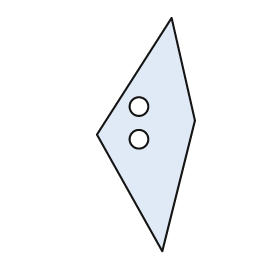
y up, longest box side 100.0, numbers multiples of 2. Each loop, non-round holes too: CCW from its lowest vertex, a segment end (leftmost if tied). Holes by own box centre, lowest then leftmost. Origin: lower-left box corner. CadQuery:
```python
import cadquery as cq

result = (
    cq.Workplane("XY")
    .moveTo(28.0, 0.0)
    .lineTo(42.0, 56.0)
    .lineTo(32.0, 100.0)
    .lineTo(0.0, 50.0)
    .close()
    .moveTo(18.0, 48.0)
    .circle(4.0)
    .moveTo(18.0, 62.0)
    .circle(4.0)
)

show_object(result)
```